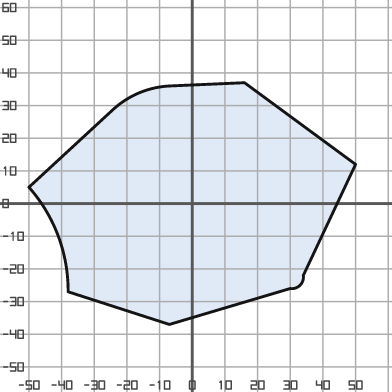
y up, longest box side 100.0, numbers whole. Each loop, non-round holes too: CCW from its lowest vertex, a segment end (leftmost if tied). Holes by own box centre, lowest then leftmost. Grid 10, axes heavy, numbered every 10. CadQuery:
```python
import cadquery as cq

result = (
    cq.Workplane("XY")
    .moveTo(-7.0, -37.0)
    .lineTo(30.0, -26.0)
    .threePointArc((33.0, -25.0), (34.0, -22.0))
    .lineTo(50.0, 12.0)
    .lineTo(16.0, 37.0)
    .lineTo(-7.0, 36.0)
    .threePointArc((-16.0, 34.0), (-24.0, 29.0))
    .lineTo(-50.0, 5.0)
    .threePointArc((-41.0, -10.0), (-38.0, -27.0))
    .close()
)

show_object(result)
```